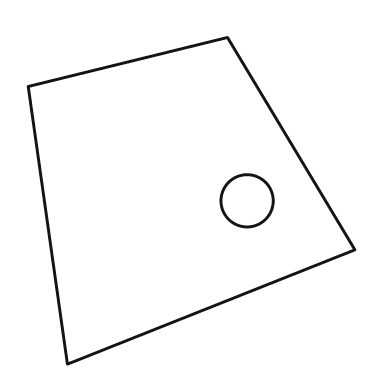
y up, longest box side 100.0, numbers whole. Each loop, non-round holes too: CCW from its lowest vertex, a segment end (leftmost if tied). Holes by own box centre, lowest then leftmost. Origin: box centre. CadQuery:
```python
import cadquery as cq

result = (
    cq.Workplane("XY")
    .moveTo(-38.0, -50.0)
    .lineTo(50.0, -15.0)
    .lineTo(11.0, 50.0)
    .lineTo(-50.0, 35.0)
    .close()
    .moveTo(17.0, 0.0)
    .circle(8.0)
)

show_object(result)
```